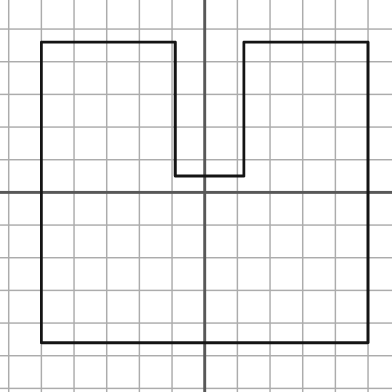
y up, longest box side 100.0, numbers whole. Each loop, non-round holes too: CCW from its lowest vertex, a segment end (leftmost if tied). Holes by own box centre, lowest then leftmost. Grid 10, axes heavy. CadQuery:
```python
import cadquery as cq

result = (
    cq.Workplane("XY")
    .moveTo(-50.0, -46.0)
    .lineTo(50.0, -46.0)
    .lineTo(50.0, 46.0)
    .lineTo(12.0, 46.0)
    .lineTo(12.0, 5.0)
    .lineTo(-9.0, 5.0)
    .lineTo(-9.0, 46.0)
    .lineTo(-50.0, 46.0)
    .close()
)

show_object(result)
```